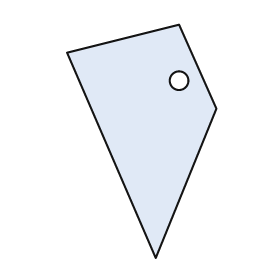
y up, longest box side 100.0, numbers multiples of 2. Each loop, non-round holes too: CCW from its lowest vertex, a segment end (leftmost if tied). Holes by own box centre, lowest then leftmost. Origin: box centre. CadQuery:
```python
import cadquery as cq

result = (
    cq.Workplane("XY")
    .moveTo(6.0, -50.0)
    .lineTo(32.0, 14.0)
    .lineTo(16.0, 50.0)
    .lineTo(-32.0, 38.0)
    .close()
    .moveTo(16.0, 26.0)
    .circle(4.0)
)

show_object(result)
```